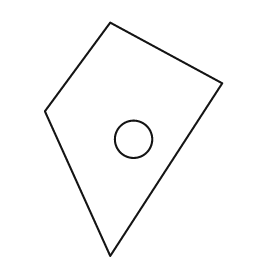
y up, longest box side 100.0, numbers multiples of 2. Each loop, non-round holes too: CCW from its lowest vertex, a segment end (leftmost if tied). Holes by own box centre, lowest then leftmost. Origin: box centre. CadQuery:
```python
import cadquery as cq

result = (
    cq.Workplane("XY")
    .moveTo(-10.0, -50.0)
    .lineTo(38.0, 24.0)
    .lineTo(-10.0, 50.0)
    .lineTo(-38.0, 12.0)
    .close()
    .moveTo(0.0, 0.0)
    .circle(8.0)
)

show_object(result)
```